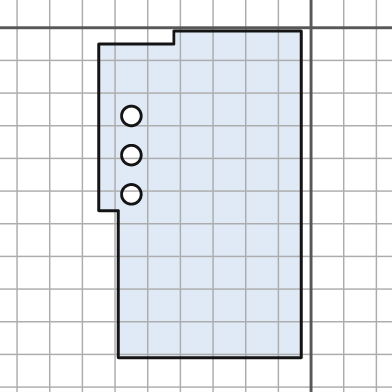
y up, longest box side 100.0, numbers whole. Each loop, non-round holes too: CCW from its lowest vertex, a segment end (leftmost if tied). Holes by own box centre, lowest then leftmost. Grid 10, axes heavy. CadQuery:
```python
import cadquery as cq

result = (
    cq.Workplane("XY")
    .moveTo(-59.0, -101.0)
    .lineTo(-3.0, -101.0)
    .lineTo(-3.0, -1.0)
    .lineTo(-42.0, -1.0)
    .lineTo(-42.0, -5.0)
    .lineTo(-65.0, -5.0)
    .lineTo(-65.0, -56.0)
    .lineTo(-59.0, -56.0)
    .close()
    .moveTo(-55.0, -51.0)
    .circle(3.0)
    .moveTo(-55.0, -39.0)
    .circle(3.0)
    .moveTo(-55.0, -27.0)
    .circle(3.0)
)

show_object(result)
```